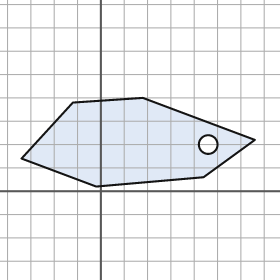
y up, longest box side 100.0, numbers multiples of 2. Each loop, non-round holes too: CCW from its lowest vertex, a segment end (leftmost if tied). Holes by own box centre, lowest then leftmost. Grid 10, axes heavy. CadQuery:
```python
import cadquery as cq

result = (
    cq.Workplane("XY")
    .moveTo(-2.0, 2.0)
    .lineTo(44.0, 6.0)
    .lineTo(66.0, 22.0)
    .lineTo(18.0, 40.0)
    .lineTo(-12.0, 38.0)
    .lineTo(-34.0, 14.0)
    .close()
    .moveTo(46.0, 20.0)
    .circle(4.0)
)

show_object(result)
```